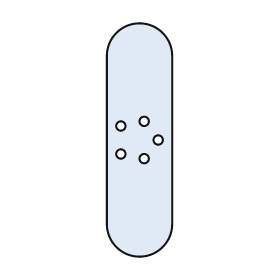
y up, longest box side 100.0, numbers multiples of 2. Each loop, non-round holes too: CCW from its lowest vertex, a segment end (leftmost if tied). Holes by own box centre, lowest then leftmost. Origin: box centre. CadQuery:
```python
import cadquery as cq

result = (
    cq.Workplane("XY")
    .moveTo(-14.0, -36.0)
    .threePointArc((0.0, -50.0), (14.0, -36.0))
    .lineTo(14.0, 36.0)
    .threePointArc((0.0, 50.0), (-14.0, 36.0))
    .close()
    .moveTo(2.0, -8.0)
    .circle(2.0)
    .moveTo(-8.0, -6.0)
    .circle(2.0)
    .moveTo(8.0, 0.0)
    .circle(2.0)
    .moveTo(-8.0, 6.0)
    .circle(2.0)
    .moveTo(2.0, 8.0)
    .circle(2.0)
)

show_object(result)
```